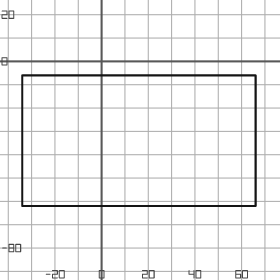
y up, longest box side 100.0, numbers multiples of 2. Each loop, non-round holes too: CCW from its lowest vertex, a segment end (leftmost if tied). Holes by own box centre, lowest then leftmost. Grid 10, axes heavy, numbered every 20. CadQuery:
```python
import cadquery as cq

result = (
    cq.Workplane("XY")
    .moveTo(-34.0, -62.0)
    .lineTo(66.0, -62.0)
    .lineTo(66.0, -6.0)
    .lineTo(-34.0, -6.0)
    .close()
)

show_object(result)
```